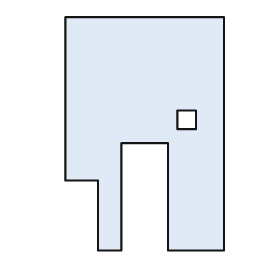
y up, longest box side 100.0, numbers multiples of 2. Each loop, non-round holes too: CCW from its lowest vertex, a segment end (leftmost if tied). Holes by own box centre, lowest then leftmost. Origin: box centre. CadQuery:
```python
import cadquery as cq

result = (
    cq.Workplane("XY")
    .moveTo(-20.0, -50.0)
    .lineTo(-10.0, -50.0)
    .lineTo(-10.0, -4.0)
    .lineTo(10.0, -4.0)
    .lineTo(10.0, -50.0)
    .lineTo(34.0, -50.0)
    .lineTo(34.0, 50.0)
    .lineTo(-34.0, 50.0)
    .lineTo(-34.0, -20.0)
    .lineTo(-20.0, -20.0)
    .close()
    .moveTo(14.0, 2.0)
    .lineTo(22.0, 2.0)
    .lineTo(22.0, 10.0)
    .lineTo(14.0, 10.0)
    .close()
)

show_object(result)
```